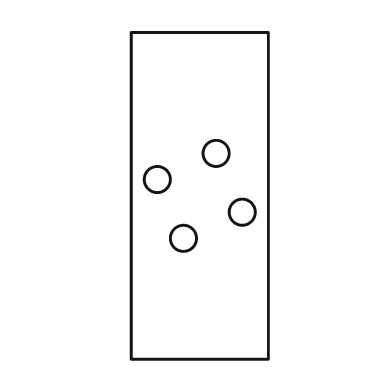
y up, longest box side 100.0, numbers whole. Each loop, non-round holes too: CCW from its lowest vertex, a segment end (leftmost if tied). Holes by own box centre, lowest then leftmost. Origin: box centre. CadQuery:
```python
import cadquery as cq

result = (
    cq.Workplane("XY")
    .moveTo(-21.0, -50.0)
    .lineTo(21.0, -50.0)
    .lineTo(21.0, 50.0)
    .lineTo(-21.0, 50.0)
    .close()
    .moveTo(-5.0, -13.0)
    .circle(4.0)
    .moveTo(13.0, -5.0)
    .circle(4.0)
    .moveTo(-13.0, 5.0)
    .circle(4.0)
    .moveTo(5.0, 13.0)
    .circle(4.0)
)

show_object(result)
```